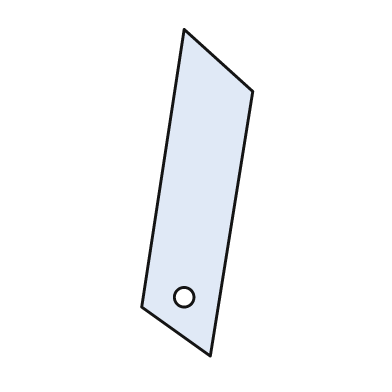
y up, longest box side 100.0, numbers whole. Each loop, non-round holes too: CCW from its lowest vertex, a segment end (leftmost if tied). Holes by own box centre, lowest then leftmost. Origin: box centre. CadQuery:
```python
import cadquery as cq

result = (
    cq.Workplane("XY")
    .moveTo(4.0, -50.0)
    .lineTo(17.0, 31.0)
    .lineTo(-4.0, 50.0)
    .lineTo(-17.0, -35.0)
    .close()
    .moveTo(-4.0, -32.0)
    .circle(3.0)
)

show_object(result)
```